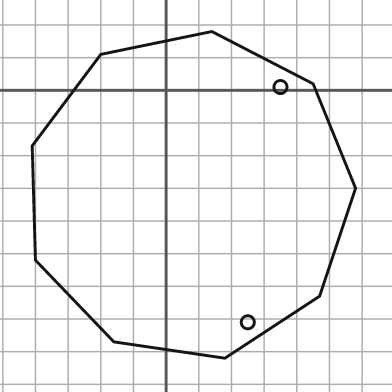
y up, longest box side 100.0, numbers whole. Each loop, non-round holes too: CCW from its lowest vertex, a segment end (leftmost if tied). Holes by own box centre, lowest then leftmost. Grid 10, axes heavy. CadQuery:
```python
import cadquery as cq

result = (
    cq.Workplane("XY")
    .moveTo(18.0, -82.0)
    .lineTo(47.0, -63.0)
    .lineTo(58.0, -30.0)
    .lineTo(45.0, 2.0)
    .lineTo(14.0, 18.0)
    .lineTo(-20.0, 11.0)
    .lineTo(-41.0, -17.0)
    .lineTo(-40.0, -52.0)
    .lineTo(-16.0, -77.0)
    .close()
    .moveTo(25.0, -71.0)
    .circle(2.0)
    .moveTo(35.0, 1.0)
    .circle(2.0)
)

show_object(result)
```